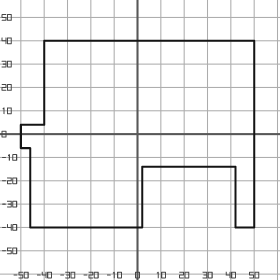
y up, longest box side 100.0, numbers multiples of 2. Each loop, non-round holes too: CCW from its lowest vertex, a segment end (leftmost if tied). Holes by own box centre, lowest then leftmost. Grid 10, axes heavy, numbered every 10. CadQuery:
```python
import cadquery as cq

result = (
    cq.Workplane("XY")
    .moveTo(-46.0, -40.0)
    .lineTo(2.0, -40.0)
    .lineTo(2.0, -14.0)
    .lineTo(42.0, -14.0)
    .lineTo(42.0, -40.0)
    .lineTo(50.0, -40.0)
    .lineTo(50.0, 40.0)
    .lineTo(-40.0, 40.0)
    .lineTo(-40.0, 4.0)
    .lineTo(-50.0, 4.0)
    .lineTo(-50.0, -6.0)
    .lineTo(-46.0, -6.0)
    .close()
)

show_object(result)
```